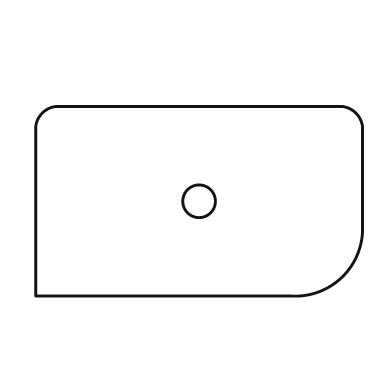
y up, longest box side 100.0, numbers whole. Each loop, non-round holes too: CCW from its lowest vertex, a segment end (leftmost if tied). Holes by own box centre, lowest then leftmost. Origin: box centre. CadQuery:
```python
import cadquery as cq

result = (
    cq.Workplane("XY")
    .moveTo(-50.0, -29.0)
    .lineTo(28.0, -29.0)
    .threePointArc((44.0, -23.0), (50.0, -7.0))
    .lineTo(50.0, 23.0)
    .threePointArc((48.0, 27.0), (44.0, 29.0))
    .lineTo(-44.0, 29.0)
    .threePointArc((-48.0, 27.0), (-50.0, 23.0))
    .close()
    .moveTo(0.0, 0.0)
    .circle(5.0)
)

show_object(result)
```